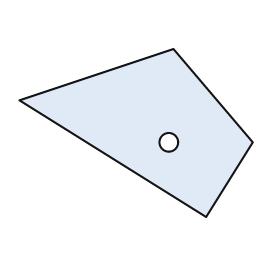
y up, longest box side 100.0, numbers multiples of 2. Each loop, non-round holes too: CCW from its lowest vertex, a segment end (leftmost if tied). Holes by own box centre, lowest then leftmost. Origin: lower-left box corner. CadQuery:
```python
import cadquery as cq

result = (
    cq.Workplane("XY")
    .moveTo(80.0, 0.0)
    .lineTo(100.0, 32.0)
    .lineTo(66.0, 72.0)
    .lineTo(0.0, 50.0)
    .close()
    .moveTo(64.0, 32.0)
    .circle(4.0)
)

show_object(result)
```